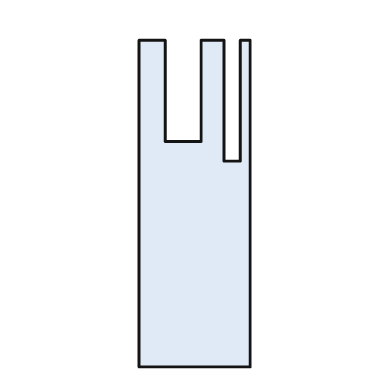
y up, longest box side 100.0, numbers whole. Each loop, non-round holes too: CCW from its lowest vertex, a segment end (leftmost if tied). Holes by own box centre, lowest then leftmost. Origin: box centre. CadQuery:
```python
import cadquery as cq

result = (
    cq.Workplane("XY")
    .moveTo(-17.0, -50.0)
    .lineTo(17.0, -50.0)
    .lineTo(17.0, 50.0)
    .lineTo(14.0, 50.0)
    .lineTo(14.0, 13.0)
    .lineTo(9.0, 13.0)
    .lineTo(9.0, 50.0)
    .lineTo(2.0, 50.0)
    .lineTo(2.0, 19.0)
    .lineTo(-9.0, 19.0)
    .lineTo(-9.0, 50.0)
    .lineTo(-17.0, 50.0)
    .close()
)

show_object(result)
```